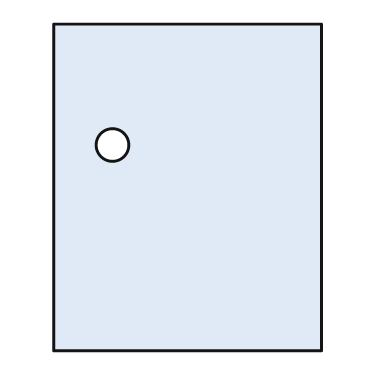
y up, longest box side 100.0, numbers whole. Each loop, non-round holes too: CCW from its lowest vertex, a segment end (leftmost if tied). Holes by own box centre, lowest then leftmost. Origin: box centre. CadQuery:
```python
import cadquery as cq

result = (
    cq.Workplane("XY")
    .moveTo(-41.0, -50.0)
    .lineTo(41.0, -50.0)
    .lineTo(41.0, 50.0)
    .lineTo(-41.0, 50.0)
    .close()
    .moveTo(-23.0, 13.0)
    .circle(5.0)
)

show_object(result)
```